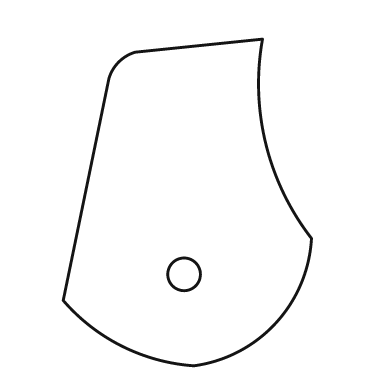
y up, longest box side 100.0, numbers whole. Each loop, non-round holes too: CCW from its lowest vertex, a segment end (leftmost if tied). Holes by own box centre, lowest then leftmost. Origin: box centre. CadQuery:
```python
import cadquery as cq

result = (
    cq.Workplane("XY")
    .moveTo(2.0, -50.0)
    .threePointArc((27.0, -37.0), (38.0, -11.0))
    .threePointArc((24.0, 18.0), (23.0, 50.0))
    .lineTo(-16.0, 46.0)
    .threePointArc((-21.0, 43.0), (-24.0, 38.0))
    .lineTo(-38.0, -30.0)
    .threePointArc((-20.0, -44.0), (2.0, -50.0))
    .close()
    .moveTo(-1.0, -22.0)
    .circle(5.0)
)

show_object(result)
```